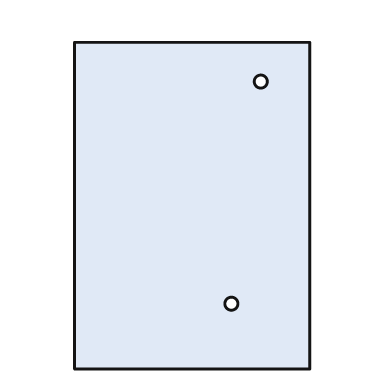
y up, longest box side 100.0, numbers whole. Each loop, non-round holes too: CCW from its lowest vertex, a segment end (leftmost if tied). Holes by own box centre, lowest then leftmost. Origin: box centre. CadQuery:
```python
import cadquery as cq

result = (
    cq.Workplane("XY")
    .moveTo(-36.0, -50.0)
    .lineTo(36.0, -50.0)
    .lineTo(36.0, 50.0)
    .lineTo(-36.0, 50.0)
    .close()
    .moveTo(12.0, -30.0)
    .circle(2.0)
    .moveTo(21.0, 38.0)
    .circle(2.0)
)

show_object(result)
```